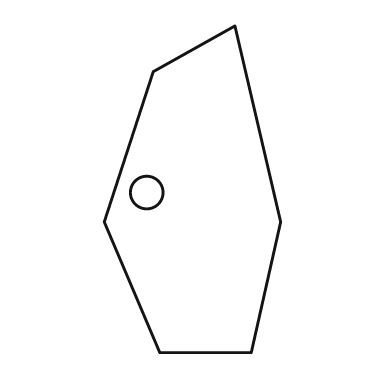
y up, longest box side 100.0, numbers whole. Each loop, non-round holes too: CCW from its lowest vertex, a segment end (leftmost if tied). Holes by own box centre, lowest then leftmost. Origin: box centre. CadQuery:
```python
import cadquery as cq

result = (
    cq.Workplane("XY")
    .moveTo(-10.0, -50.0)
    .lineTo(18.0, -50.0)
    .lineTo(27.0, -10.0)
    .lineTo(13.0, 50.0)
    .lineTo(-12.0, 36.0)
    .lineTo(-27.0, -10.0)
    .close()
    .moveTo(-14.0, -1.0)
    .circle(5.0)
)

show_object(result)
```